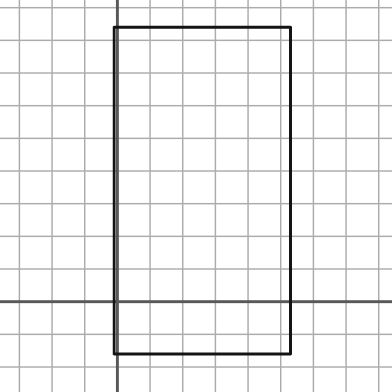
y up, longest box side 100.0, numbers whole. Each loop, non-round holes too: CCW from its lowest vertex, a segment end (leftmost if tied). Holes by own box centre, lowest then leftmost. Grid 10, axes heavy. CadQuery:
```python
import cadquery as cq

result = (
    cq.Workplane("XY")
    .moveTo(-1.0, -16.0)
    .lineTo(53.0, -16.0)
    .lineTo(53.0, 84.0)
    .lineTo(-1.0, 84.0)
    .close()
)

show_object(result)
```